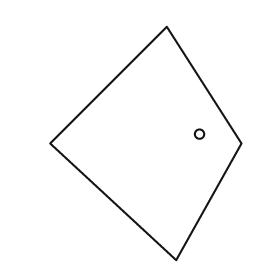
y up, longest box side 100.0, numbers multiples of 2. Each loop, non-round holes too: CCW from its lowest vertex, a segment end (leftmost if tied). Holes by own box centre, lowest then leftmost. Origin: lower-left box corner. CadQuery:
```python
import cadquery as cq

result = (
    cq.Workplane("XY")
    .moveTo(54.0, 0.0)
    .lineTo(82.0, 50.0)
    .lineTo(50.0, 100.0)
    .lineTo(0.0, 50.0)
    .close()
    .moveTo(64.0, 54.0)
    .circle(2.0)
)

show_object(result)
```